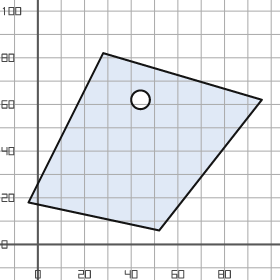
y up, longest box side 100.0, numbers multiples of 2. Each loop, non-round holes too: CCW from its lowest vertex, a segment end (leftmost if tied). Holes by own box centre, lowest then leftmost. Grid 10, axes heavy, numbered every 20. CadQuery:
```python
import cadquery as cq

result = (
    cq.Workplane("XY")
    .moveTo(52.0, 6.0)
    .lineTo(96.0, 62.0)
    .lineTo(28.0, 82.0)
    .lineTo(-4.0, 18.0)
    .close()
    .moveTo(44.0, 62.0)
    .circle(4.0)
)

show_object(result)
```